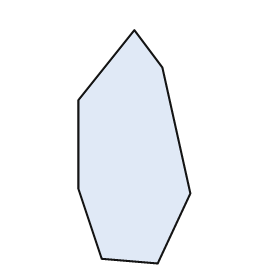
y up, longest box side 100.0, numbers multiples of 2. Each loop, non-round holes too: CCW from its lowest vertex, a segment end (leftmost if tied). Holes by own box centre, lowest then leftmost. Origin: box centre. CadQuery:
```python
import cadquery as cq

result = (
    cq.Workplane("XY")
    .moveTo(10.0, -50.0)
    .lineTo(24.0, -20.0)
    .lineTo(12.0, 34.0)
    .lineTo(0.0, 50.0)
    .lineTo(-24.0, 20.0)
    .lineTo(-24.0, -18.0)
    .lineTo(-14.0, -48.0)
    .close()
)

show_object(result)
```